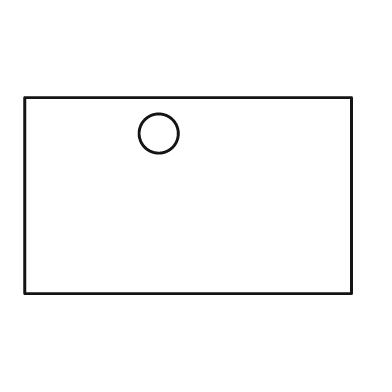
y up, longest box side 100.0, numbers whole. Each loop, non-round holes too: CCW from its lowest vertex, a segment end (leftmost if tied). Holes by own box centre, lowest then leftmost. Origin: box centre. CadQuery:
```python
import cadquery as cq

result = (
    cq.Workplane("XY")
    .moveTo(-50.0, -30.0)
    .lineTo(50.0, -30.0)
    .lineTo(50.0, 30.0)
    .lineTo(-50.0, 30.0)
    .close()
    .moveTo(-9.0, 19.0)
    .circle(6.0)
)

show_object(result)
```